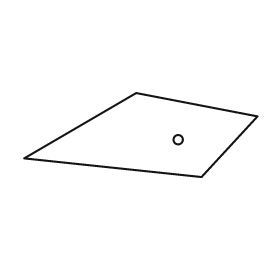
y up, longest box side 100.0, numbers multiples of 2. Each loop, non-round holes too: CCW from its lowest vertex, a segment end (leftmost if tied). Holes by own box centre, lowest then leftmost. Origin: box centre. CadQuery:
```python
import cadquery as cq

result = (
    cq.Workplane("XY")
    .moveTo(26.0, -18.0)
    .lineTo(50.0, 8.0)
    .lineTo(-2.0, 18.0)
    .lineTo(-50.0, -10.0)
    .close()
    .moveTo(16.0, -2.0)
    .circle(2.0)
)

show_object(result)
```